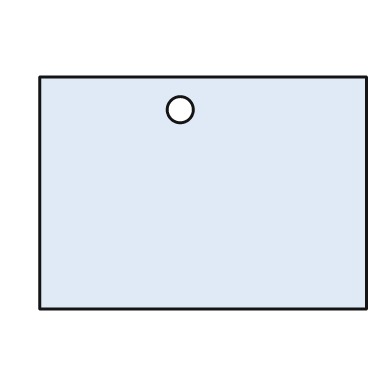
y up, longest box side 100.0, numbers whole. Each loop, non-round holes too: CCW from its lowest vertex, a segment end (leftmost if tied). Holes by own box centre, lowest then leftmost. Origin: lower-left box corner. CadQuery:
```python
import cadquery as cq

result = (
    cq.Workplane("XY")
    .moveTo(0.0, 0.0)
    .lineTo(100.0, 0.0)
    .lineTo(100.0, 71.0)
    .lineTo(0.0, 71.0)
    .close()
    .moveTo(43.0, 61.0)
    .circle(4.0)
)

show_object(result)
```